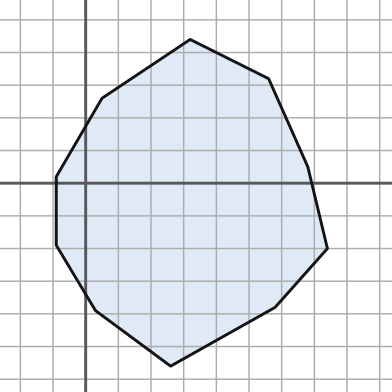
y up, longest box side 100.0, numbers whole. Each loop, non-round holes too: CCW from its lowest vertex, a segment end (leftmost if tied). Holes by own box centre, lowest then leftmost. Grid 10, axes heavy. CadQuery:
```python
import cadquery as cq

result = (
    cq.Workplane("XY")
    .moveTo(26.0, -56.0)
    .lineTo(58.0, -38.0)
    .lineTo(74.0, -20.0)
    .lineTo(68.0, 5.0)
    .lineTo(56.0, 32.0)
    .lineTo(32.0, 44.0)
    .lineTo(5.0, 26.0)
    .lineTo(-9.0, 2.0)
    .lineTo(-9.0, -19.0)
    .lineTo(3.0, -39.0)
    .close()
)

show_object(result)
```